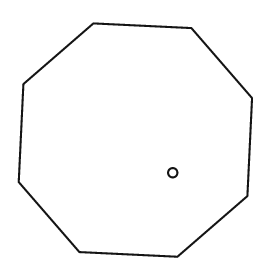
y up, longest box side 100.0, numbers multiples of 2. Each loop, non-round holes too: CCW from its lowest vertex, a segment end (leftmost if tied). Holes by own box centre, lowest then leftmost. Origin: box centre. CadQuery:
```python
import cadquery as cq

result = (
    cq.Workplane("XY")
    .moveTo(18.0, -50.0)
    .lineTo(48.0, -24.0)
    .lineTo(50.0, 18.0)
    .lineTo(24.0, 48.0)
    .lineTo(-18.0, 50.0)
    .lineTo(-48.0, 24.0)
    .lineTo(-50.0, -18.0)
    .lineTo(-24.0, -48.0)
    .close()
    .moveTo(16.0, -14.0)
    .circle(2.0)
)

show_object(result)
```